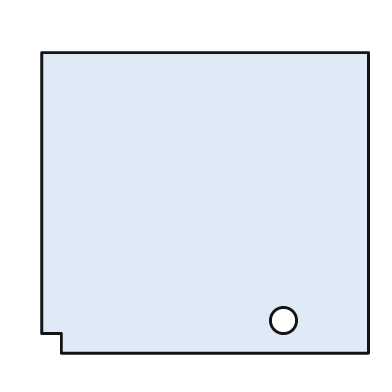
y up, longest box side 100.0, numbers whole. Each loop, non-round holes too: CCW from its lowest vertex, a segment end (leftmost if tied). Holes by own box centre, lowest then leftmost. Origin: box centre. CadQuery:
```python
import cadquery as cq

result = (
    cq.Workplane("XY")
    .moveTo(-44.0, -46.0)
    .lineTo(50.0, -46.0)
    .lineTo(50.0, 46.0)
    .lineTo(-50.0, 46.0)
    .lineTo(-50.0, -40.0)
    .lineTo(-44.0, -40.0)
    .close()
    .moveTo(24.0, -36.0)
    .circle(4.0)
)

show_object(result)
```